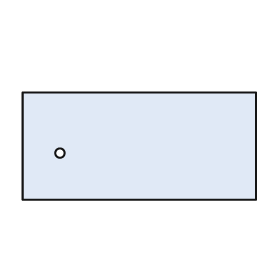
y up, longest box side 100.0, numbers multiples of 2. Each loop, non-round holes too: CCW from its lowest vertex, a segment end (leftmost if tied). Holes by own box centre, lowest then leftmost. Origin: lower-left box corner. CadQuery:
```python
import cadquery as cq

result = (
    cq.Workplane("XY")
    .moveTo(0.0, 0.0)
    .lineTo(100.0, 0.0)
    .lineTo(100.0, 46.0)
    .lineTo(0.0, 46.0)
    .close()
    .moveTo(16.0, 20.0)
    .circle(2.0)
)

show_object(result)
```